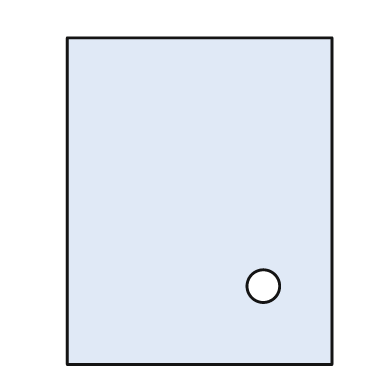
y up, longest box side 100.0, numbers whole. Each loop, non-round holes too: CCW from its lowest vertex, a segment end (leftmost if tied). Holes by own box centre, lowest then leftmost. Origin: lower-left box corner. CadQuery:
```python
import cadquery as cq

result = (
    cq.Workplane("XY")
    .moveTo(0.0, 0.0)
    .lineTo(81.0, 0.0)
    .lineTo(81.0, 100.0)
    .lineTo(0.0, 100.0)
    .close()
    .moveTo(60.0, 24.0)
    .circle(5.0)
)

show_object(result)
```